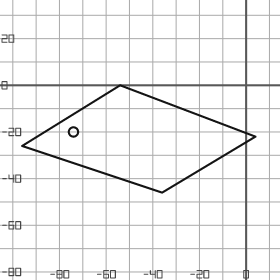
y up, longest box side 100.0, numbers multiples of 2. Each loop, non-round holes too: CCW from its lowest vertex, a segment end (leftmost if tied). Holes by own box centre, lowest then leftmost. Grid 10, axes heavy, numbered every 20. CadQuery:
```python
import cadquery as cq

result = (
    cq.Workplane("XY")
    .moveTo(-36.0, -46.0)
    .lineTo(4.0, -22.0)
    .lineTo(-54.0, 0.0)
    .lineTo(-96.0, -26.0)
    .close()
    .moveTo(-74.0, -20.0)
    .circle(2.0)
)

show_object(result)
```